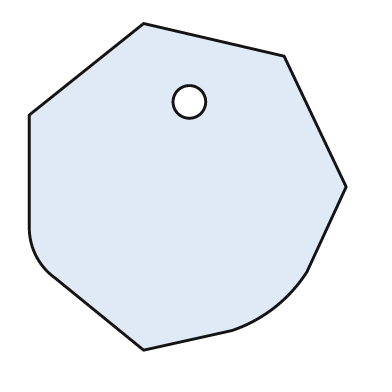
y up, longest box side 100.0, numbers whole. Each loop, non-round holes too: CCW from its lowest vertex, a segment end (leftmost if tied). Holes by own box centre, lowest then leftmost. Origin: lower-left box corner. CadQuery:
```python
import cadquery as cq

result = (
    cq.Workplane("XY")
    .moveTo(35.0, 0.0)
    .lineTo(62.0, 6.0)
    .threePointArc((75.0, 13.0), (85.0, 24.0))
    .lineTo(97.0, 50.0)
    .lineTo(78.0, 90.0)
    .lineTo(35.0, 100.0)
    .lineTo(0.0, 72.0)
    .lineTo(0.0, 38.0)
    .threePointArc((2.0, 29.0), (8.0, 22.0))
    .close()
    .moveTo(49.0, 76.0)
    .circle(5.0)
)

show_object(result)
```